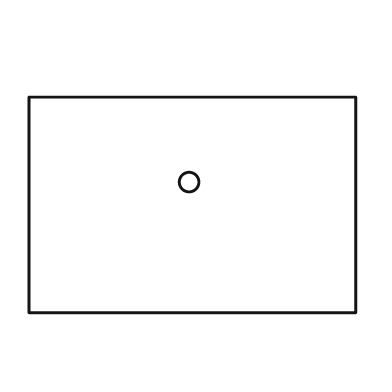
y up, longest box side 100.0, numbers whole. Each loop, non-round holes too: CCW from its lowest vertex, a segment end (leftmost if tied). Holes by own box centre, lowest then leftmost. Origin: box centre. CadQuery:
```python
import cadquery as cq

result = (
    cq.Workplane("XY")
    .moveTo(-50.0, -33.0)
    .lineTo(50.0, -33.0)
    .lineTo(50.0, 33.0)
    .lineTo(-50.0, 33.0)
    .close()
    .moveTo(-1.0, 7.0)
    .circle(3.0)
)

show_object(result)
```